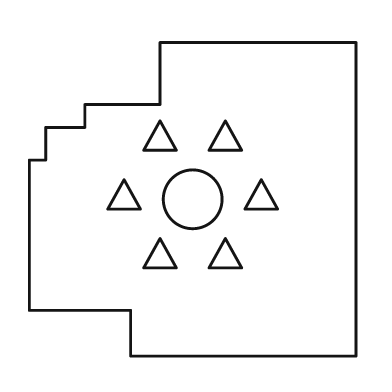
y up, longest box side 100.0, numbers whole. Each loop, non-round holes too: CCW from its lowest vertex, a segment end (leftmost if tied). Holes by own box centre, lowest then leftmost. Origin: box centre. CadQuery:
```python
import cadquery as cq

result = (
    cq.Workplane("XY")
    .moveTo(-19.0, -48.0)
    .lineTo(50.0, -48.0)
    .lineTo(50.0, 48.0)
    .lineTo(-10.0, 48.0)
    .lineTo(-10.0, 29.0)
    .lineTo(-33.0, 29.0)
    .lineTo(-33.0, 22.0)
    .lineTo(-45.0, 22.0)
    .lineTo(-45.0, 12.0)
    .lineTo(-50.0, 12.0)
    .lineTo(-50.0, -34.0)
    .lineTo(-19.0, -34.0)
    .close()
    .moveTo(-15.0, -21.0)
    .lineTo(-5.0, -21.0)
    .lineTo(-10.0, -12.0)
    .close()
    .moveTo(5.0, -21.0)
    .lineTo(15.0, -21.0)
    .lineTo(10.0, -12.0)
    .close()
    .moveTo(0.0, 0.0)
    .circle(9.0)
    .moveTo(-26.0, -3.0)
    .lineTo(-16.0, -3.0)
    .lineTo(-21.0, 6.0)
    .close()
    .moveTo(16.0, -3.0)
    .lineTo(26.0, -3.0)
    .lineTo(21.0, 6.0)
    .close()
    .moveTo(-15.0, 15.0)
    .lineTo(-5.0, 15.0)
    .lineTo(-10.0, 24.0)
    .close()
    .moveTo(5.0, 15.0)
    .lineTo(15.0, 15.0)
    .lineTo(10.0, 24.0)
    .close()
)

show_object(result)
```